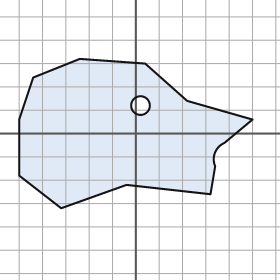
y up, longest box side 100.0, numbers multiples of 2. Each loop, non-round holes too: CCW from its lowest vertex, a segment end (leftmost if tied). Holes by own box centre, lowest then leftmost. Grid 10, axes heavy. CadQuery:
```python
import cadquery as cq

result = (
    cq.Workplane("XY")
    .moveTo(-32.0, -32.0)
    .lineTo(-4.0, -22.0)
    .lineTo(32.0, -26.0)
    .lineTo(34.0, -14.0)
    .threePointArc((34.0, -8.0), (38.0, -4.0))
    .lineTo(50.0, 6.0)
    .lineTo(22.0, 14.0)
    .lineTo(4.0, 30.0)
    .lineTo(-24.0, 32.0)
    .lineTo(-44.0, 24.0)
    .lineTo(-50.0, 6.0)
    .lineTo(-50.0, -18.0)
    .close()
    .moveTo(2.0, 12.0)
    .circle(4.0)
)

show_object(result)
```